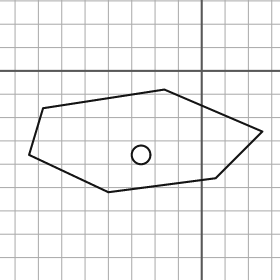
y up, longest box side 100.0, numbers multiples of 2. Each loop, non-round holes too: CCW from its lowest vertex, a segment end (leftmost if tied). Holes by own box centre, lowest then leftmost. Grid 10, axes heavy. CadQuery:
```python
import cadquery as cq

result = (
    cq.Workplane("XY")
    .moveTo(-40.0, -52.0)
    .lineTo(6.0, -46.0)
    .lineTo(26.0, -26.0)
    .lineTo(-16.0, -8.0)
    .lineTo(-68.0, -16.0)
    .lineTo(-74.0, -36.0)
    .close()
    .moveTo(-26.0, -36.0)
    .circle(4.0)
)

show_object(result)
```